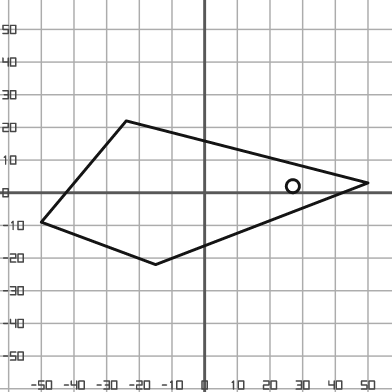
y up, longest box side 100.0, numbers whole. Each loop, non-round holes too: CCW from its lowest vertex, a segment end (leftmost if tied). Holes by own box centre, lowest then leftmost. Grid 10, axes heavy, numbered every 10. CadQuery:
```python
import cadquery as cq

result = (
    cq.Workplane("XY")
    .moveTo(-15.0, -22.0)
    .lineTo(50.0, 3.0)
    .lineTo(-24.0, 22.0)
    .lineTo(-50.0, -9.0)
    .close()
    .moveTo(27.0, 2.0)
    .circle(2.0)
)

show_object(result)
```